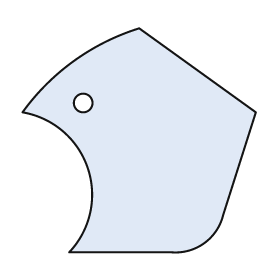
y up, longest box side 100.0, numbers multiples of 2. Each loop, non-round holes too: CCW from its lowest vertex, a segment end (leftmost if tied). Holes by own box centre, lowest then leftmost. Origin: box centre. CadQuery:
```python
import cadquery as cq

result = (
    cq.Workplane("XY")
    .moveTo(-30.0, -48.0)
    .lineTo(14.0, -48.0)
    .threePointArc((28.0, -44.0), (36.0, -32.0))
    .lineTo(50.0, 12.0)
    .lineTo(0.0, 48.0)
    .threePointArc((-28.0, 34.0), (-50.0, 12.0))
    .threePointArc((-22.0, -12.0), (-30.0, -48.0))
    .close()
    .moveTo(-24.0, 16.0)
    .circle(4.0)
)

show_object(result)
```